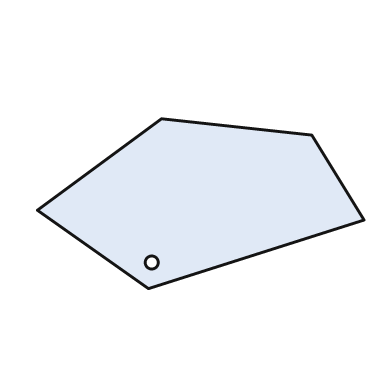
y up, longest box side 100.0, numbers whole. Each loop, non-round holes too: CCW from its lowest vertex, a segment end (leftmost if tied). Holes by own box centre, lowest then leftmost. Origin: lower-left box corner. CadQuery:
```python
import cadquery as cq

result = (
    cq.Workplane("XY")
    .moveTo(34.0, 0.0)
    .lineTo(100.0, 21.0)
    .lineTo(84.0, 47.0)
    .lineTo(38.0, 52.0)
    .lineTo(0.0, 24.0)
    .close()
    .moveTo(35.0, 8.0)
    .circle(2.0)
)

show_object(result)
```